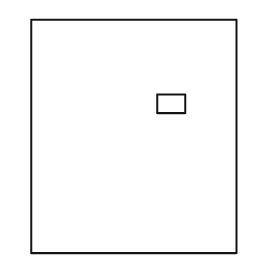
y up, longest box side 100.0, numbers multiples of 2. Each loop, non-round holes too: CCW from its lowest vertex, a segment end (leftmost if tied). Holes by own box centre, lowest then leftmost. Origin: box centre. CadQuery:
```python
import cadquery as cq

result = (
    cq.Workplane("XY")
    .moveTo(-44.0, -50.0)
    .lineTo(44.0, -50.0)
    .lineTo(44.0, 50.0)
    .lineTo(-44.0, 50.0)
    .close()
    .moveTo(10.0, 10.0)
    .lineTo(22.0, 10.0)
    .lineTo(22.0, 18.0)
    .lineTo(10.0, 18.0)
    .close()
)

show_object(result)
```